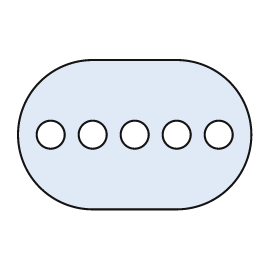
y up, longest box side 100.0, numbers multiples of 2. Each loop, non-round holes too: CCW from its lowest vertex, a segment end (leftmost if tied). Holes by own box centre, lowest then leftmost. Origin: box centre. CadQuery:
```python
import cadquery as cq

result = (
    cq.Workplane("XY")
    .moveTo(-18.0, -32.0)
    .lineTo(18.0, -32.0)
    .threePointArc((50.0, 0.0), (18.0, 32.0))
    .lineTo(-18.0, 32.0)
    .threePointArc((-50.0, 0.0), (-18.0, -32.0))
    .close()
    .moveTo(-36.0, 0.0)
    .circle(6.0)
    .moveTo(-18.0, 0.0)
    .circle(6.0)
    .moveTo(0.0, 0.0)
    .circle(6.0)
    .moveTo(18.0, 0.0)
    .circle(6.0)
    .moveTo(36.0, 0.0)
    .circle(6.0)
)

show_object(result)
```